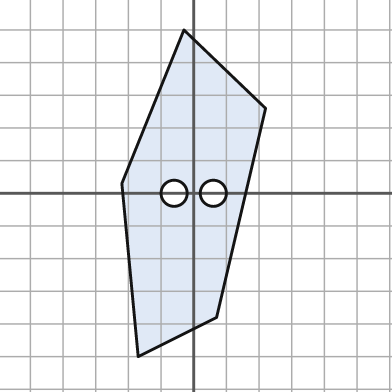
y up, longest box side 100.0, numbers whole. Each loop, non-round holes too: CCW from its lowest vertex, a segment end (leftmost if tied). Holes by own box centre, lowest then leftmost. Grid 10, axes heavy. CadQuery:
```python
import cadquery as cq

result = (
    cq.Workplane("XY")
    .moveTo(-17.0, -50.0)
    .lineTo(7.0, -38.0)
    .lineTo(22.0, 26.0)
    .lineTo(-3.0, 50.0)
    .lineTo(-22.0, 3.0)
    .close()
    .moveTo(-6.0, 0.0)
    .circle(4.0)
    .moveTo(6.0, 0.0)
    .circle(4.0)
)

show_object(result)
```